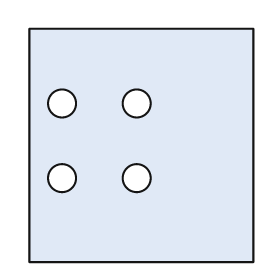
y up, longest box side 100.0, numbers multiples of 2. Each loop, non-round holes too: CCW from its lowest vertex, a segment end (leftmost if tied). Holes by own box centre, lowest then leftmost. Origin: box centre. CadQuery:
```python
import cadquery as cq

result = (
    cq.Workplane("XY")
    .moveTo(-48.0, -50.0)
    .lineTo(48.0, -50.0)
    .lineTo(48.0, 50.0)
    .lineTo(-48.0, 50.0)
    .close()
    .moveTo(-34.0, -14.0)
    .circle(6.0)
    .moveTo(-2.0, -14.0)
    .circle(6.0)
    .moveTo(-34.0, 18.0)
    .circle(6.0)
    .moveTo(-2.0, 18.0)
    .circle(6.0)
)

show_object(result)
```